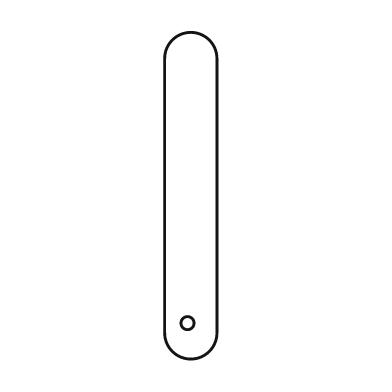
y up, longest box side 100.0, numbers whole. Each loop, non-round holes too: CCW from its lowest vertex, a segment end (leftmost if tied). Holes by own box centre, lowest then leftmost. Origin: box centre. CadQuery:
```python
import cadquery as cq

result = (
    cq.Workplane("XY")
    .moveTo(-8.0, -42.0)
    .threePointArc((0.0, -50.0), (8.0, -42.0))
    .lineTo(8.0, 42.0)
    .threePointArc((0.0, 50.0), (-8.0, 42.0))
    .close()
    .moveTo(-1.0, -39.0)
    .circle(2.0)
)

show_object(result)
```